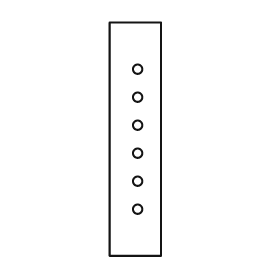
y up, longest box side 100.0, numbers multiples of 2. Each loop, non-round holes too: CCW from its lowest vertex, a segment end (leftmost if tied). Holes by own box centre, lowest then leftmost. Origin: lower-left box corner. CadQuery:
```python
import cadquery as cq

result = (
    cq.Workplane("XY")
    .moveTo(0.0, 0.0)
    .lineTo(22.0, 0.0)
    .lineTo(22.0, 100.0)
    .lineTo(0.0, 100.0)
    .close()
    .moveTo(12.0, 20.0)
    .circle(2.0)
    .moveTo(12.0, 32.0)
    .circle(2.0)
    .moveTo(12.0, 44.0)
    .circle(2.0)
    .moveTo(12.0, 56.0)
    .circle(2.0)
    .moveTo(12.0, 68.0)
    .circle(2.0)
    .moveTo(12.0, 80.0)
    .circle(2.0)
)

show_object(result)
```